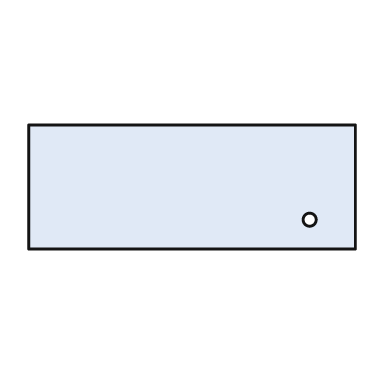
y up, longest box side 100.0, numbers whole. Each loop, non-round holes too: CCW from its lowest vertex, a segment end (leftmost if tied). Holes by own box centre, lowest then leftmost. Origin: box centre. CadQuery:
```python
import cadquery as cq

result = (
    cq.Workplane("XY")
    .moveTo(-50.0, -19.0)
    .lineTo(50.0, -19.0)
    .lineTo(50.0, 19.0)
    .lineTo(-50.0, 19.0)
    .close()
    .moveTo(36.0, -10.0)
    .circle(2.0)
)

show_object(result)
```